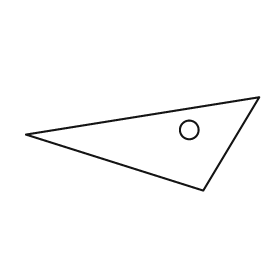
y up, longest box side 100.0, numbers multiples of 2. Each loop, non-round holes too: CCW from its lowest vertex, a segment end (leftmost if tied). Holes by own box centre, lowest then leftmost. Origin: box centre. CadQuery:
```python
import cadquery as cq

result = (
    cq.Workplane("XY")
    .moveTo(26.0, -20.0)
    .lineTo(50.0, 20.0)
    .lineTo(-50.0, 4.0)
    .close()
    .moveTo(20.0, 6.0)
    .circle(4.0)
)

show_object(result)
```